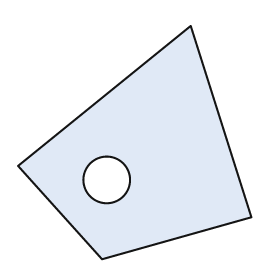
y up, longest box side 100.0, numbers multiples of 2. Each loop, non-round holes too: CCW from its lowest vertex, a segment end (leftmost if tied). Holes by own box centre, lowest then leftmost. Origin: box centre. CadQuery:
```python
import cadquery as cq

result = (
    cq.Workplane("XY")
    .moveTo(-14.0, -50.0)
    .lineTo(50.0, -32.0)
    .lineTo(24.0, 50.0)
    .lineTo(-50.0, -10.0)
    .close()
    .moveTo(-12.0, -16.0)
    .circle(10.0)
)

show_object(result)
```